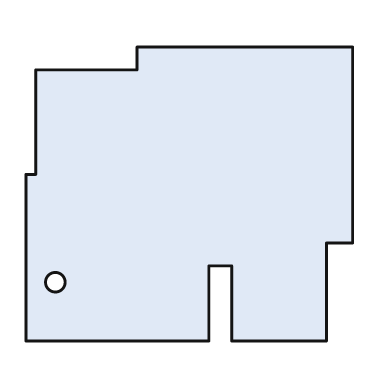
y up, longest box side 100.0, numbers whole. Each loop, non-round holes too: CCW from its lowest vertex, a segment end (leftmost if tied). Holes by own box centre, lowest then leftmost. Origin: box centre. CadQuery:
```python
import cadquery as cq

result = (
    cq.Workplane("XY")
    .moveTo(-50.0, -45.0)
    .lineTo(6.0, -45.0)
    .lineTo(6.0, -22.0)
    .lineTo(13.0, -22.0)
    .lineTo(13.0, -45.0)
    .lineTo(42.0, -45.0)
    .lineTo(42.0, -15.0)
    .lineTo(50.0, -15.0)
    .lineTo(50.0, 45.0)
    .lineTo(-16.0, 45.0)
    .lineTo(-16.0, 38.0)
    .lineTo(-47.0, 38.0)
    .lineTo(-47.0, 6.0)
    .lineTo(-50.0, 6.0)
    .close()
    .moveTo(-41.0, -27.0)
    .circle(3.0)
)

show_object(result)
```